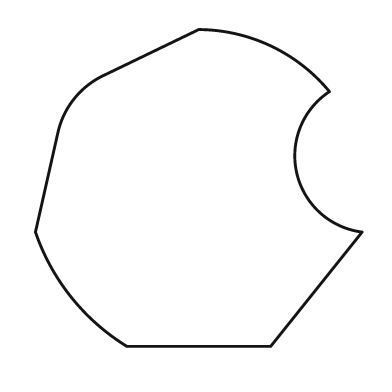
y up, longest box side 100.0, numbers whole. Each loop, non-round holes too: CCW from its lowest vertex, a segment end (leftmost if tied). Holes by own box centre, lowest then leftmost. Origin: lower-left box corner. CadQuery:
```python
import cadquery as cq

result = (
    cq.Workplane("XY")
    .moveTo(28.0, 0.0)
    .lineTo(72.0, 0.0)
    .lineTo(100.0, 35.0)
    .threePointArc((80.0, 53.0), (90.0, 78.0))
    .threePointArc((72.0, 92.0), (50.0, 97.0))
    .lineTo(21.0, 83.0)
    .threePointArc((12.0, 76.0), (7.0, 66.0))
    .lineTo(0.0, 35.0)
    .threePointArc((11.0, 15.0), (28.0, 0.0))
    .close()
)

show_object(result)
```